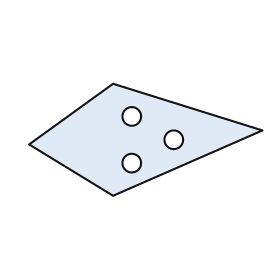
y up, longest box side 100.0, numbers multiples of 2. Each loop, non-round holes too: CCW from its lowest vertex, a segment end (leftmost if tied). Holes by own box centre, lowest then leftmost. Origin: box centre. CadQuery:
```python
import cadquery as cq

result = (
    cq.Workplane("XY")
    .moveTo(-14.0, -24.0)
    .lineTo(50.0, 4.0)
    .lineTo(-14.0, 24.0)
    .lineTo(-50.0, -2.0)
    .close()
    .moveTo(-6.0, -10.0)
    .circle(4.0)
    .moveTo(12.0, 0.0)
    .circle(4.0)
    .moveTo(-6.0, 10.0)
    .circle(4.0)
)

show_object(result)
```